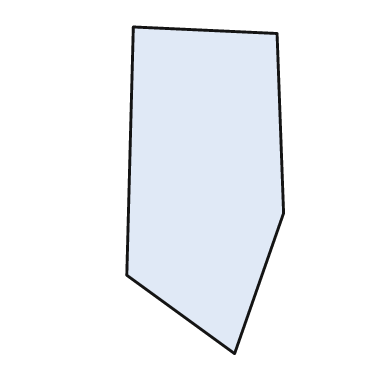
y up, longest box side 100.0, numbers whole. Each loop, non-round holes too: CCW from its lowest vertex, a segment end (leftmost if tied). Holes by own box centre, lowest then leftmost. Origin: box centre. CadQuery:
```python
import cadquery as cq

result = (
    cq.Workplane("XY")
    .moveTo(9.0, -50.0)
    .lineTo(24.0, -7.0)
    .lineTo(22.0, 48.0)
    .lineTo(-22.0, 50.0)
    .lineTo(-24.0, -26.0)
    .close()
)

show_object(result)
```